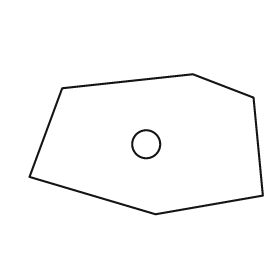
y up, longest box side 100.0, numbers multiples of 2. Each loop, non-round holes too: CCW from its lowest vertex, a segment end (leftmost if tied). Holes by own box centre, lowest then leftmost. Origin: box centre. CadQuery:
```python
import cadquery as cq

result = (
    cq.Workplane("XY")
    .moveTo(4.0, -30.0)
    .lineTo(50.0, -22.0)
    .lineTo(46.0, 20.0)
    .lineTo(20.0, 30.0)
    .lineTo(-36.0, 24.0)
    .lineTo(-50.0, -14.0)
    .close()
    .moveTo(0.0, 0.0)
    .circle(6.0)
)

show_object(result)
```